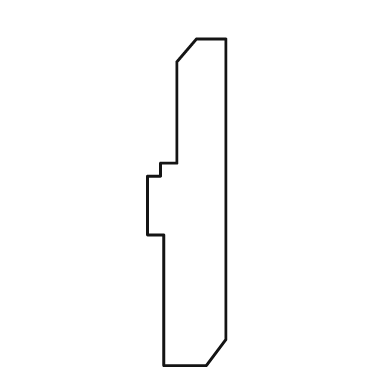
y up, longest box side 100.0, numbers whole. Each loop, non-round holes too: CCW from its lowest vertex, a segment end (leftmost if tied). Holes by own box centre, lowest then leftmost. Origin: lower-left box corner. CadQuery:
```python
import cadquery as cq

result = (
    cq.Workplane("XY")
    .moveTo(5.0, 0.0)
    .lineTo(18.0, 0.0)
    .lineTo(24.0, 8.0)
    .lineTo(24.0, 100.0)
    .lineTo(15.0, 100.0)
    .lineTo(9.0, 93.0)
    .lineTo(9.0, 62.0)
    .lineTo(4.0, 62.0)
    .lineTo(4.0, 58.0)
    .lineTo(0.0, 58.0)
    .lineTo(0.0, 40.0)
    .lineTo(5.0, 40.0)
    .close()
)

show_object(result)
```